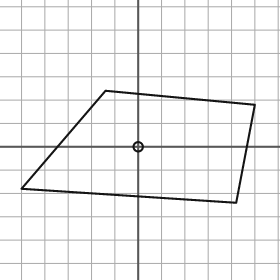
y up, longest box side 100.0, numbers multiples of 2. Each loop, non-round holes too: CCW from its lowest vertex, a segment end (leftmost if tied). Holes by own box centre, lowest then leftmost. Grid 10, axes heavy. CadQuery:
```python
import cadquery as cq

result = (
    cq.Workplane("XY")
    .moveTo(42.0, -24.0)
    .lineTo(50.0, 18.0)
    .lineTo(-14.0, 24.0)
    .lineTo(-50.0, -18.0)
    .close()
    .moveTo(0.0, 0.0)
    .circle(2.0)
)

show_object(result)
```